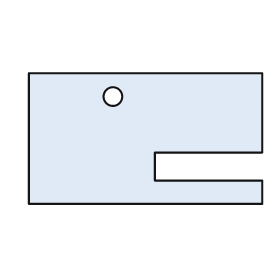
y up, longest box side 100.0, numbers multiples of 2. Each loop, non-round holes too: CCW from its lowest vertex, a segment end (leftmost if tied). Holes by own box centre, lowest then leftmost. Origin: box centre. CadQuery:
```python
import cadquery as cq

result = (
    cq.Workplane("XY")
    .moveTo(-50.0, -28.0)
    .lineTo(50.0, -28.0)
    .lineTo(50.0, -18.0)
    .lineTo(4.0, -18.0)
    .lineTo(4.0, -6.0)
    .lineTo(50.0, -6.0)
    .lineTo(50.0, 28.0)
    .lineTo(-50.0, 28.0)
    .close()
    .moveTo(-14.0, 18.0)
    .circle(4.0)
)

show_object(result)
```